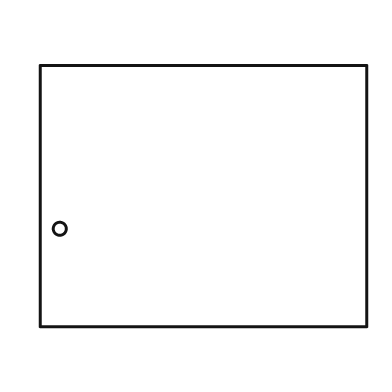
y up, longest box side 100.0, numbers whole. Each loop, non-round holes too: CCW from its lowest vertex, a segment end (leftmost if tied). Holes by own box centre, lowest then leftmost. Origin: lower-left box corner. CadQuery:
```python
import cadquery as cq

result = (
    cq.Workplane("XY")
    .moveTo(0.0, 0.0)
    .lineTo(100.0, 0.0)
    .lineTo(100.0, 80.0)
    .lineTo(0.0, 80.0)
    .close()
    .moveTo(6.0, 30.0)
    .circle(2.0)
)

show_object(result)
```